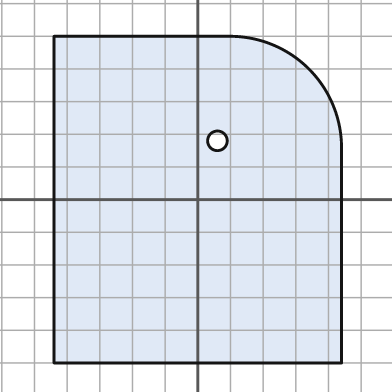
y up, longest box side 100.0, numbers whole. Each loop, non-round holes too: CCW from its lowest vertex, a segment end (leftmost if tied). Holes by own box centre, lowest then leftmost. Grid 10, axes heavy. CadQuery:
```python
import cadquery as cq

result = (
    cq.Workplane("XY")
    .moveTo(-44.0, -50.0)
    .lineTo(44.0, -50.0)
    .lineTo(44.0, 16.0)
    .threePointArc((34.0, 40.0), (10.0, 50.0))
    .lineTo(-44.0, 50.0)
    .close()
    .moveTo(6.0, 18.0)
    .circle(3.0)
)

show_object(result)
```